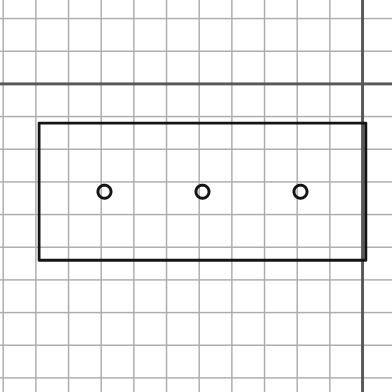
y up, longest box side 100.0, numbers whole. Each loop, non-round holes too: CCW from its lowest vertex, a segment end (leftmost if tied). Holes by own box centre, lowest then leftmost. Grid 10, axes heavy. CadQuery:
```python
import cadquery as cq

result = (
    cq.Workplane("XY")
    .moveTo(-99.0, -54.0)
    .lineTo(1.0, -54.0)
    .lineTo(1.0, -12.0)
    .lineTo(-99.0, -12.0)
    .close()
    .moveTo(-79.0, -33.0)
    .circle(2.0)
    .moveTo(-49.0, -33.0)
    .circle(2.0)
    .moveTo(-19.0, -33.0)
    .circle(2.0)
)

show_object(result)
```